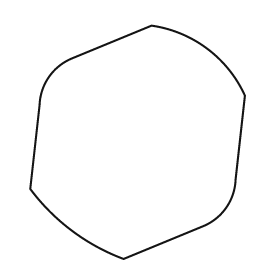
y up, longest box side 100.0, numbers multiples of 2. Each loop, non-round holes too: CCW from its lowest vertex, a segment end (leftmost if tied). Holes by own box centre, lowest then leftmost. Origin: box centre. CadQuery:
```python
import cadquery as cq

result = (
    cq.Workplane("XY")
    .moveTo(-6.0, -50.0)
    .lineTo(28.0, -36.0)
    .threePointArc((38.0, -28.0), (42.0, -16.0))
    .lineTo(46.0, 20.0)
    .threePointArc((30.0, 40.0), (6.0, 50.0))
    .lineTo(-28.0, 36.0)
    .threePointArc((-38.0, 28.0), (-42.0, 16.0))
    .lineTo(-46.0, -20.0)
    .threePointArc((-28.0, -38.0), (-6.0, -50.0))
    .close()
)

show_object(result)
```